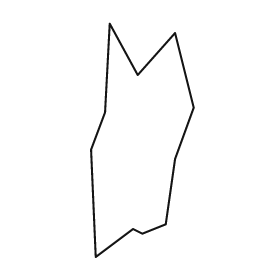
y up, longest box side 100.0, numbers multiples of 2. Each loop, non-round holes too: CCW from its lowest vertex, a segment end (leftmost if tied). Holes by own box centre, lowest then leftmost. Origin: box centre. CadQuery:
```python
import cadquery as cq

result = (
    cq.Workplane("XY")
    .moveTo(-20.0, -50.0)
    .lineTo(-4.0, -38.0)
    .lineTo(0.0, -40.0)
    .lineTo(10.0, -36.0)
    .lineTo(14.0, -8.0)
    .lineTo(22.0, 14.0)
    .lineTo(14.0, 46.0)
    .lineTo(-2.0, 28.0)
    .lineTo(-14.0, 50.0)
    .lineTo(-16.0, 12.0)
    .lineTo(-22.0, -4.0)
    .close()
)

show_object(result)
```